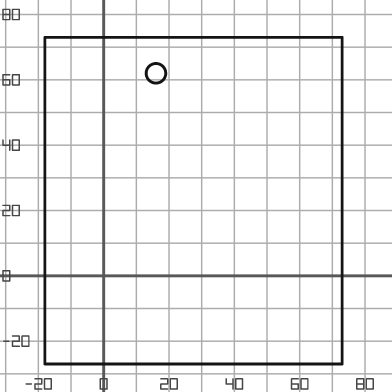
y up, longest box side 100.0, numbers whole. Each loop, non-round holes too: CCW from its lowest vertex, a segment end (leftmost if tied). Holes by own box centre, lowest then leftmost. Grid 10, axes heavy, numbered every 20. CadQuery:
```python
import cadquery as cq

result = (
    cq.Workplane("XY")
    .moveTo(-18.0, -27.0)
    .lineTo(73.0, -27.0)
    .lineTo(73.0, 73.0)
    .lineTo(-18.0, 73.0)
    .close()
    .moveTo(16.0, 62.0)
    .circle(3.0)
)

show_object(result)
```